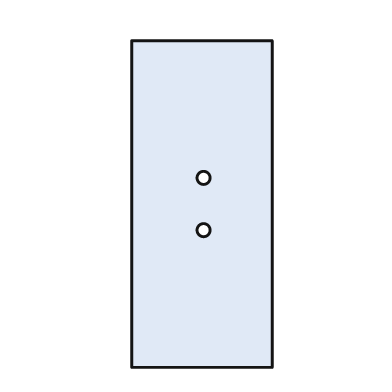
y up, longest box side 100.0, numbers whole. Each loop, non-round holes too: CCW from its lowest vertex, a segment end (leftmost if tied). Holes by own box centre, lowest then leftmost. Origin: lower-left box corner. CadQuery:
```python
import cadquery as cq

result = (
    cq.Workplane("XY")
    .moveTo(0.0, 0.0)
    .lineTo(43.0, 0.0)
    .lineTo(43.0, 100.0)
    .lineTo(0.0, 100.0)
    .close()
    .moveTo(22.0, 42.0)
    .circle(2.0)
    .moveTo(22.0, 58.0)
    .circle(2.0)
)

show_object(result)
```